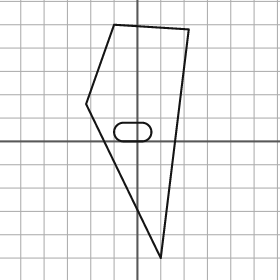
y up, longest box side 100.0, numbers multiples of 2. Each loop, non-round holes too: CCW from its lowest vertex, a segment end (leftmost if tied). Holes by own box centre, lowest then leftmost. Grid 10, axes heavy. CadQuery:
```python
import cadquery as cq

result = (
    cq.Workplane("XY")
    .moveTo(10.0, -50.0)
    .lineTo(22.0, 48.0)
    .lineTo(-10.0, 50.0)
    .lineTo(-22.0, 16.0)
    .close()
    .moveTo(-6.0, 0.0)
    .lineTo(2.0, 0.0)
    .threePointArc((6.0, 4.0), (2.0, 8.0))
    .lineTo(-6.0, 8.0)
    .threePointArc((-10.0, 4.0), (-6.0, 0.0))
    .close()
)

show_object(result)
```